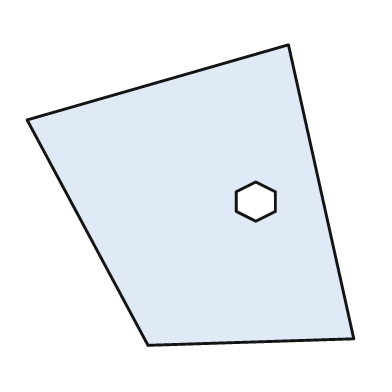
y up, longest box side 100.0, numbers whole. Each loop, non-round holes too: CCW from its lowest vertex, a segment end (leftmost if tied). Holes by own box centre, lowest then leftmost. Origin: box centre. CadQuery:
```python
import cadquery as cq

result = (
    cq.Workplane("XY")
    .moveTo(-13.0, -46.0)
    .lineTo(50.0, -44.0)
    .lineTo(30.0, 46.0)
    .lineTo(-50.0, 23.0)
    .close()
    .moveTo(20.0, -8.0)
    .lineTo(26.0, -5.0)
    .lineTo(26.0, 1.0)
    .lineTo(20.0, 4.0)
    .lineTo(14.0, 1.0)
    .lineTo(14.0, -5.0)
    .close()
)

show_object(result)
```